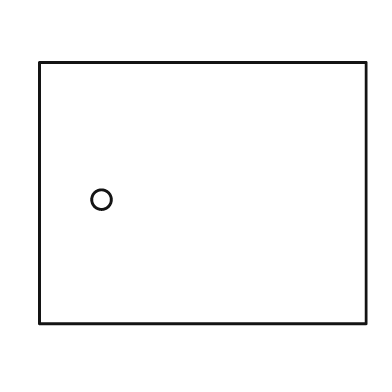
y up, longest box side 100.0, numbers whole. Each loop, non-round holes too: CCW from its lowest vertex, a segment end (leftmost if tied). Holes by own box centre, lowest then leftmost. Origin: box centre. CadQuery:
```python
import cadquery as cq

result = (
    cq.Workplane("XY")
    .moveTo(-50.0, -40.0)
    .lineTo(50.0, -40.0)
    .lineTo(50.0, 40.0)
    .lineTo(-50.0, 40.0)
    .close()
    .moveTo(-31.0, -2.0)
    .circle(3.0)
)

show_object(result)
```